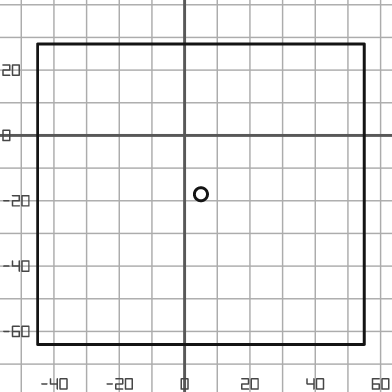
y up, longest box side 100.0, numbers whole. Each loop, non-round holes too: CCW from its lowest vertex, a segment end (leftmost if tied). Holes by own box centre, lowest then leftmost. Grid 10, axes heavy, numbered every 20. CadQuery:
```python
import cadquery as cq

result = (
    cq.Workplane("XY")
    .moveTo(-45.0, -64.0)
    .lineTo(55.0, -64.0)
    .lineTo(55.0, 28.0)
    .lineTo(-45.0, 28.0)
    .close()
    .moveTo(5.0, -18.0)
    .circle(2.0)
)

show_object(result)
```